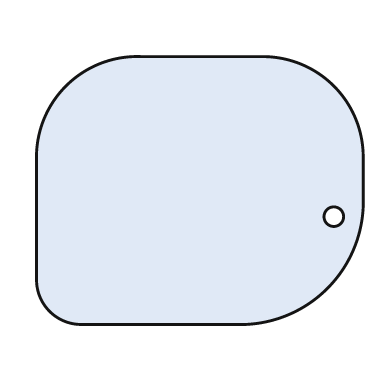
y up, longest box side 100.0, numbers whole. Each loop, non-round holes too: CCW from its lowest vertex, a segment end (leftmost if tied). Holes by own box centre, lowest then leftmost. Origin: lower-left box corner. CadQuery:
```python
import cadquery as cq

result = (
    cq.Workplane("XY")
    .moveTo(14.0, 0.0)
    .lineTo(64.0, 0.0)
    .threePointArc((89.0, 11.0), (100.0, 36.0))
    .lineTo(100.0, 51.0)
    .threePointArc((91.0, 73.0), (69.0, 82.0))
    .lineTo(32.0, 82.0)
    .threePointArc((9.0, 73.0), (0.0, 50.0))
    .lineTo(0.0, 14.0)
    .threePointArc((4.0, 4.0), (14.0, 0.0))
    .close()
    .moveTo(91.0, 33.0)
    .circle(3.0)
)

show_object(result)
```